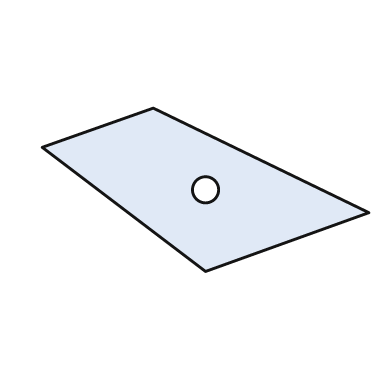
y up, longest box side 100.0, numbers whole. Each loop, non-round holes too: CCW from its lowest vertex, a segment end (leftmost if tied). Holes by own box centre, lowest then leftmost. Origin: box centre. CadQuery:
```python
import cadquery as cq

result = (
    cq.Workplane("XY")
    .moveTo(0.0, -25.0)
    .lineTo(50.0, -7.0)
    .lineTo(-16.0, 25.0)
    .lineTo(-50.0, 13.0)
    .close()
    .moveTo(0.0, 0.0)
    .circle(4.0)
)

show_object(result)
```